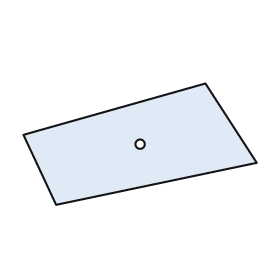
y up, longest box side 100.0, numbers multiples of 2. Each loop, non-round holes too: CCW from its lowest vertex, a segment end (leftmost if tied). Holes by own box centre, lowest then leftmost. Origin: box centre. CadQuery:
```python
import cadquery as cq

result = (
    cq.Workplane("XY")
    .moveTo(-36.0, -26.0)
    .lineTo(50.0, -8.0)
    .lineTo(28.0, 26.0)
    .lineTo(-50.0, 4.0)
    .close()
    .moveTo(0.0, 0.0)
    .circle(2.0)
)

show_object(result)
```